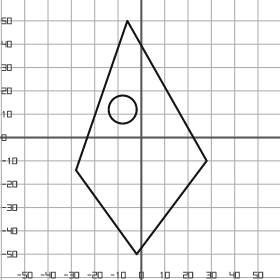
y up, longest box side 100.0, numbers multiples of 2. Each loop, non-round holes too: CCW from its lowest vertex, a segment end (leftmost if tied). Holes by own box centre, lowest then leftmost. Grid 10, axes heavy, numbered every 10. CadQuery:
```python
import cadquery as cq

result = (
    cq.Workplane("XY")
    .moveTo(-2.0, -50.0)
    .lineTo(28.0, -10.0)
    .lineTo(-6.0, 50.0)
    .lineTo(-28.0, -14.0)
    .close()
    .moveTo(-8.0, 12.0)
    .circle(6.0)
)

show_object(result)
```